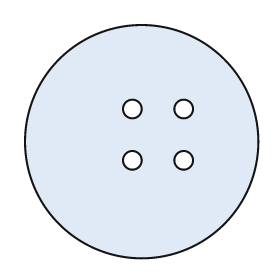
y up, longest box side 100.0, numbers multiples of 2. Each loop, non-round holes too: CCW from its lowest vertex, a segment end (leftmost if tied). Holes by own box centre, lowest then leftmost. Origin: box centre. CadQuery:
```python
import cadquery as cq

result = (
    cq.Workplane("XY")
    .moveTo(0.0, 0.0)
    .circle(50.0)
    .moveTo(-4.0, -8.0)
    .circle(4.0)
    .moveTo(18.0, -8.0)
    .circle(4.0)
    .moveTo(-4.0, 14.0)
    .circle(4.0)
    .moveTo(18.0, 14.0)
    .circle(4.0)
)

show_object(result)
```